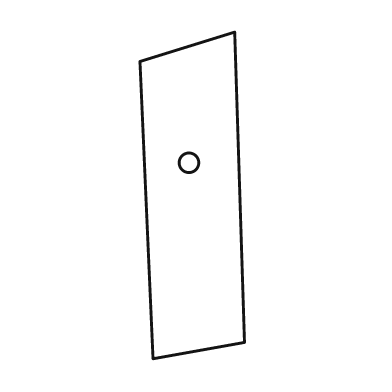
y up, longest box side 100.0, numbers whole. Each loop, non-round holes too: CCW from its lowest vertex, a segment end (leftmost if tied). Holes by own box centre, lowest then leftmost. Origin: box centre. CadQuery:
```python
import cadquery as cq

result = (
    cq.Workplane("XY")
    .moveTo(-12.0, -50.0)
    .lineTo(16.0, -45.0)
    .lineTo(13.0, 50.0)
    .lineTo(-16.0, 41.0)
    .close()
    .moveTo(-1.0, 10.0)
    .circle(3.0)
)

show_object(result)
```